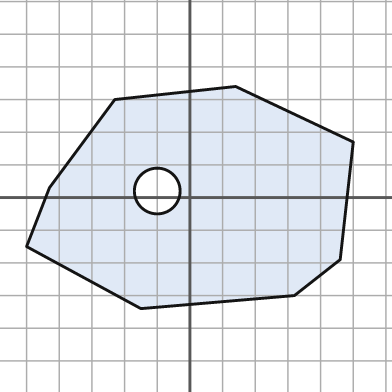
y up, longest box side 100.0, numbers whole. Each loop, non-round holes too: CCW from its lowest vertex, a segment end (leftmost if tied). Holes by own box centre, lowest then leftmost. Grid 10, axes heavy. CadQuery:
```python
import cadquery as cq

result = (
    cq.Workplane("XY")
    .moveTo(-15.0, -34.0)
    .lineTo(32.0, -30.0)
    .lineTo(46.0, -19.0)
    .lineTo(50.0, 17.0)
    .lineTo(14.0, 34.0)
    .lineTo(-23.0, 30.0)
    .lineTo(-43.0, 3.0)
    .lineTo(-50.0, -15.0)
    .close()
    .moveTo(-10.0, 2.0)
    .circle(7.0)
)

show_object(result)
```